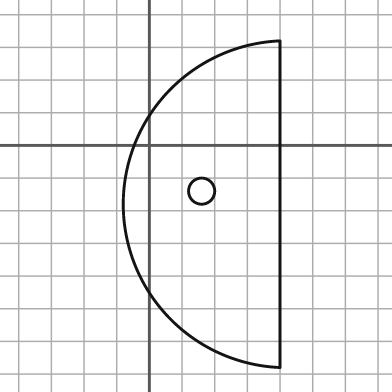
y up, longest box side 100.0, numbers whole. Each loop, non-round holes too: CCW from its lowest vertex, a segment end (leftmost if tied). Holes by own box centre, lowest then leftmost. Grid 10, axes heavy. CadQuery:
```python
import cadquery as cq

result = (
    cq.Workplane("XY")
    .moveTo(40.0, -68.0)
    .lineTo(40.0, 32.0)
    .threePointArc((-8.0, -18.0), (40.0, -68.0))
    .close()
    .moveTo(16.0, -14.0)
    .circle(4.0)
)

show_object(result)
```